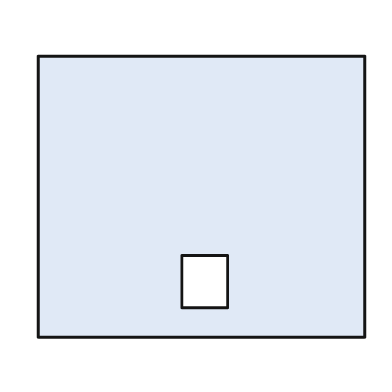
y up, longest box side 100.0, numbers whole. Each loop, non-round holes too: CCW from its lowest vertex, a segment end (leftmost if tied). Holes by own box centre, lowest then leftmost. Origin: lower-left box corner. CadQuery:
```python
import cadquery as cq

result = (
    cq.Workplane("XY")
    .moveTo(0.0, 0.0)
    .lineTo(100.0, 0.0)
    .lineTo(100.0, 86.0)
    .lineTo(0.0, 86.0)
    .close()
    .moveTo(44.0, 9.0)
    .lineTo(58.0, 9.0)
    .lineTo(58.0, 25.0)
    .lineTo(44.0, 25.0)
    .close()
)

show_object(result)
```